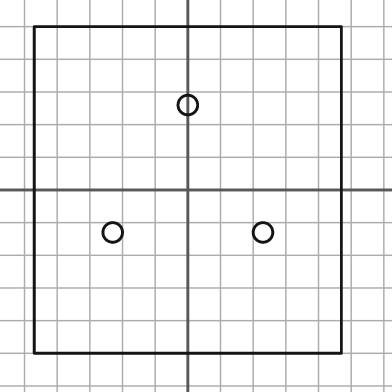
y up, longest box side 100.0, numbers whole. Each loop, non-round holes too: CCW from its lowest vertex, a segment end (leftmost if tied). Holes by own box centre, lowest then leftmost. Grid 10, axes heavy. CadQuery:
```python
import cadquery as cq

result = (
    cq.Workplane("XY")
    .moveTo(-47.0, -50.0)
    .lineTo(47.0, -50.0)
    .lineTo(47.0, 50.0)
    .lineTo(-47.0, 50.0)
    .close()
    .moveTo(-23.0, -13.0)
    .circle(3.0)
    .moveTo(23.0, -13.0)
    .circle(3.0)
    .moveTo(0.0, 26.0)
    .circle(3.0)
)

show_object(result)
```